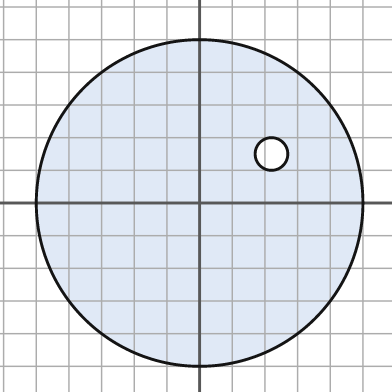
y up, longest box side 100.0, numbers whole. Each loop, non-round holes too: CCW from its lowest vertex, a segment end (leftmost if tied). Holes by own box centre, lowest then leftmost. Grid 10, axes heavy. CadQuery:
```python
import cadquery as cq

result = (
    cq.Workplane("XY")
    .moveTo(0.0, 0.0)
    .circle(50.0)
    .moveTo(22.0, 15.0)
    .circle(5.0)
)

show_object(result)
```